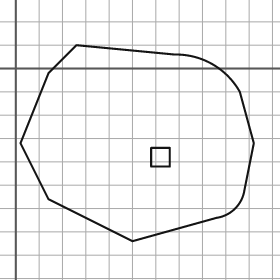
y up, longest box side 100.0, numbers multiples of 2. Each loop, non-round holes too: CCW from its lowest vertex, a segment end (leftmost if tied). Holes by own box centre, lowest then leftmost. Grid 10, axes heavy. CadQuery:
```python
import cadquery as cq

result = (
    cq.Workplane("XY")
    .moveTo(50.0, -74.0)
    .lineTo(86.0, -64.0)
    .threePointArc((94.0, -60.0), (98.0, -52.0))
    .lineTo(102.0, -32.0)
    .lineTo(96.0, -10.0)
    .threePointArc((84.0, 2.0), (68.0, 6.0))
    .lineTo(26.0, 10.0)
    .lineTo(14.0, -2.0)
    .lineTo(2.0, -32.0)
    .lineTo(14.0, -56.0)
    .close()
    .moveTo(58.0, -42.0)
    .lineTo(66.0, -42.0)
    .lineTo(66.0, -34.0)
    .lineTo(58.0, -34.0)
    .close()
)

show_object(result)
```